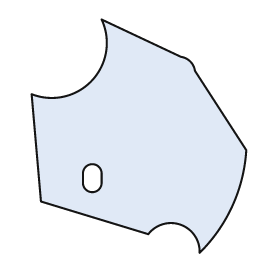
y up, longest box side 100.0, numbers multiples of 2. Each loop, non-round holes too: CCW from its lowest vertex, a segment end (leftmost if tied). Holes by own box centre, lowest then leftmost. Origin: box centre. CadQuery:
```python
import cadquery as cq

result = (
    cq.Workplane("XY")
    .moveTo(26.0, -50.0)
    .threePointArc((40.0, -30.0), (46.0, -6.0))
    .lineTo(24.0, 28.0)
    .threePointArc((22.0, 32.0), (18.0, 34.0))
    .lineTo(-16.0, 50.0)
    .threePointArc((-20.0, 24.0), (-46.0, 18.0))
    .lineTo(-42.0, -28.0)
    .lineTo(4.0, -42.0)
    .threePointArc((18.0, -38.0), (26.0, -50.0))
    .close()
    .moveTo(-24.0, -20.0)
    .threePointArc((-20.0, -24.0), (-16.0, -20.0))
    .lineTo(-16.0, -16.0)
    .threePointArc((-20.0, -12.0), (-24.0, -16.0))
    .close()
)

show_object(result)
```